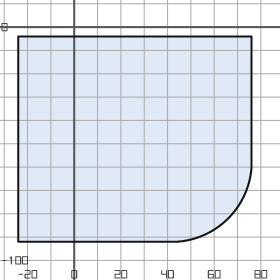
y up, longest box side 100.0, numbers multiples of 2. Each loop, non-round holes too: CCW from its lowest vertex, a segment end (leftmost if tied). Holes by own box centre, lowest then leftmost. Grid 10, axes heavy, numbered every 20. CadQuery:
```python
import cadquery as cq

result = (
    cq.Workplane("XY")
    .moveTo(-24.0, -92.0)
    .lineTo(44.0, -92.0)
    .threePointArc((66.0, -82.0), (76.0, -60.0))
    .lineTo(76.0, -4.0)
    .lineTo(-24.0, -4.0)
    .close()
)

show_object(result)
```